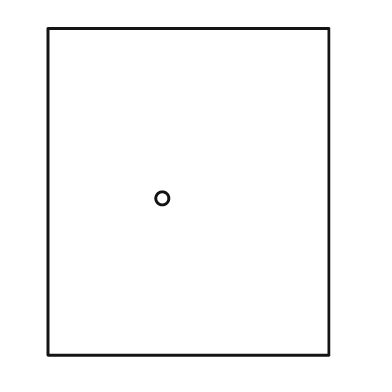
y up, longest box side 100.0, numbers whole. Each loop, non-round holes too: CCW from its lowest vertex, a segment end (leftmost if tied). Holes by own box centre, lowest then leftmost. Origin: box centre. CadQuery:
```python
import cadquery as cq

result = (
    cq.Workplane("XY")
    .moveTo(-43.0, -50.0)
    .lineTo(43.0, -50.0)
    .lineTo(43.0, 50.0)
    .lineTo(-43.0, 50.0)
    .close()
    .moveTo(-8.0, -2.0)
    .circle(2.0)
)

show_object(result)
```